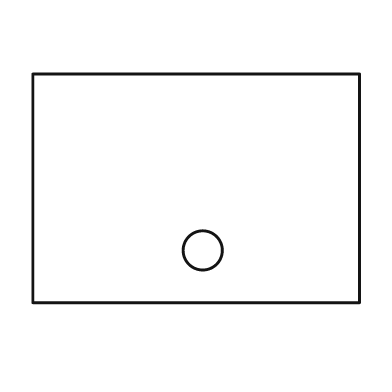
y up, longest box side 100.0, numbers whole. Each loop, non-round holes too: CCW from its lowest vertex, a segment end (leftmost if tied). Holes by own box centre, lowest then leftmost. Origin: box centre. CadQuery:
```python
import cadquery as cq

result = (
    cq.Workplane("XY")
    .moveTo(-50.0, -35.0)
    .lineTo(50.0, -35.0)
    .lineTo(50.0, 35.0)
    .lineTo(-50.0, 35.0)
    .close()
    .moveTo(2.0, -19.0)
    .circle(6.0)
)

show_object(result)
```